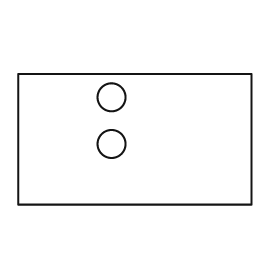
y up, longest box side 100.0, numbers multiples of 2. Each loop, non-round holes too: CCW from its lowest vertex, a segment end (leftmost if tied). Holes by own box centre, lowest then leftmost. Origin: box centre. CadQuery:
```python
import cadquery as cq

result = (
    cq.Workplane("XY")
    .moveTo(-50.0, -28.0)
    .lineTo(50.0, -28.0)
    .lineTo(50.0, 28.0)
    .lineTo(-50.0, 28.0)
    .close()
    .moveTo(-10.0, -2.0)
    .circle(6.0)
    .moveTo(-10.0, 18.0)
    .circle(6.0)
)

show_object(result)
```